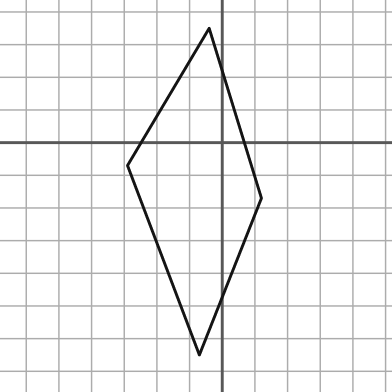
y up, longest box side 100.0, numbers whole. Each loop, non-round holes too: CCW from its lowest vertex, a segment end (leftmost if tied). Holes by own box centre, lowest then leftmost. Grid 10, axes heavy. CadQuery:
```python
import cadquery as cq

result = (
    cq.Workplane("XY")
    .moveTo(-7.0, -65.0)
    .lineTo(12.0, -17.0)
    .lineTo(-4.0, 35.0)
    .lineTo(-29.0, -7.0)
    .close()
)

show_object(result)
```